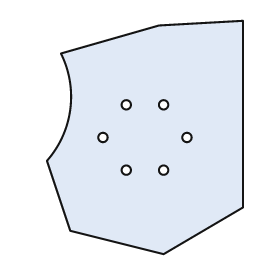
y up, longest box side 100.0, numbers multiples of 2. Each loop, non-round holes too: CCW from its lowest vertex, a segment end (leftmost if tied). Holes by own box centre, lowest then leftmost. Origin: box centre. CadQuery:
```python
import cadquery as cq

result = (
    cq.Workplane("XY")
    .moveTo(8.0, -50.0)
    .lineTo(42.0, -30.0)
    .lineTo(42.0, 50.0)
    .lineTo(6.0, 48.0)
    .lineTo(-36.0, 36.0)
    .threePointArc((-32.0, 12.0), (-42.0, -10.0))
    .lineTo(-32.0, -40.0)
    .close()
    .moveTo(-8.0, -14.0)
    .circle(2.0)
    .moveTo(8.0, -14.0)
    .circle(2.0)
    .moveTo(-18.0, 0.0)
    .circle(2.0)
    .moveTo(18.0, 0.0)
    .circle(2.0)
    .moveTo(-8.0, 14.0)
    .circle(2.0)
    .moveTo(8.0, 14.0)
    .circle(2.0)
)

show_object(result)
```